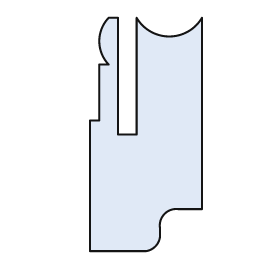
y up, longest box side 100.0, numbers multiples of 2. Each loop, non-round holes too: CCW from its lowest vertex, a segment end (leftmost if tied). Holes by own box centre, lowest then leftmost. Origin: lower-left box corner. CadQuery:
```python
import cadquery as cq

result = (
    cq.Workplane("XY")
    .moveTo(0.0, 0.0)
    .lineTo(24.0, 0.0)
    .threePointArc((28.0, 2.0), (30.0, 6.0))
    .lineTo(30.0, 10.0)
    .threePointArc((32.0, 16.0), (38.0, 18.0))
    .lineTo(48.0, 18.0)
    .lineTo(48.0, 100.0)
    .threePointArc((34.0, 92.0), (20.0, 100.0))
    .lineTo(20.0, 50.0)
    .lineTo(12.0, 50.0)
    .lineTo(12.0, 100.0)
    .lineTo(8.0, 100.0)
    .threePointArc((4.0, 90.0), (8.0, 80.0))
    .lineTo(4.0, 80.0)
    .lineTo(4.0, 56.0)
    .lineTo(0.0, 56.0)
    .close()
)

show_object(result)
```